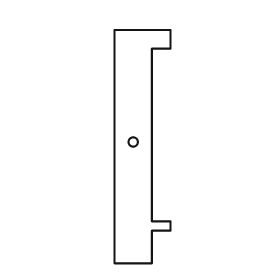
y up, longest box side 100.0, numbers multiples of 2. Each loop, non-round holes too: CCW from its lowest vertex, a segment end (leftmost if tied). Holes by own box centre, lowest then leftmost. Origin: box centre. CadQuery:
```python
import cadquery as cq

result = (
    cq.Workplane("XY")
    .moveTo(-12.0, -50.0)
    .lineTo(4.0, -50.0)
    .lineTo(4.0, -36.0)
    .lineTo(12.0, -36.0)
    .lineTo(12.0, -32.0)
    .lineTo(4.0, -32.0)
    .lineTo(4.0, 42.0)
    .lineTo(12.0, 42.0)
    .lineTo(12.0, 50.0)
    .lineTo(-12.0, 50.0)
    .close()
    .moveTo(-4.0, 2.0)
    .circle(2.0)
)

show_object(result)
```